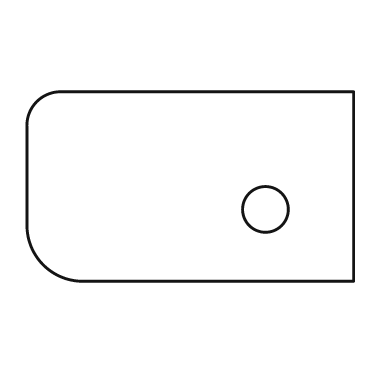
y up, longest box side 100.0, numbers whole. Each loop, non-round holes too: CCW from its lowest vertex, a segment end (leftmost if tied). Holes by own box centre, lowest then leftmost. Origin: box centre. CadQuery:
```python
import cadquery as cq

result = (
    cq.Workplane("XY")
    .moveTo(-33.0, -29.0)
    .lineTo(50.0, -29.0)
    .lineTo(50.0, 29.0)
    .lineTo(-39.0, 29.0)
    .threePointArc((-47.0, 26.0), (-50.0, 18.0))
    .lineTo(-50.0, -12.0)
    .threePointArc((-45.0, -24.0), (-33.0, -29.0))
    .close()
    .moveTo(23.0, -7.0)
    .circle(7.0)
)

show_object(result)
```